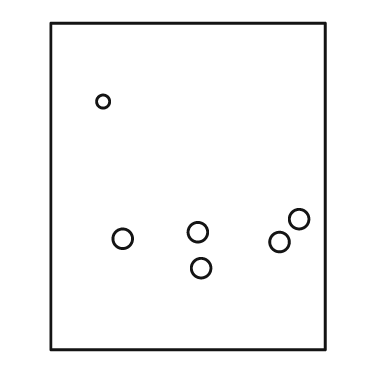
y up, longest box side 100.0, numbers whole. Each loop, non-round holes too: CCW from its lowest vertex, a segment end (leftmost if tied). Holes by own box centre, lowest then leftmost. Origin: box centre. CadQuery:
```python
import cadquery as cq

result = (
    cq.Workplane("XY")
    .moveTo(-42.0, -50.0)
    .lineTo(42.0, -50.0)
    .lineTo(42.0, 50.0)
    .lineTo(-42.0, 50.0)
    .close()
    .moveTo(4.0, -25.0)
    .circle(3.0)
    .moveTo(28.0, -17.0)
    .circle(3.0)
    .moveTo(-20.0, -16.0)
    .circle(3.0)
    .moveTo(3.0, -14.0)
    .circle(3.0)
    .moveTo(34.0, -10.0)
    .circle(3.0)
    .moveTo(-26.0, 26.0)
    .circle(2.0)
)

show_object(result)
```